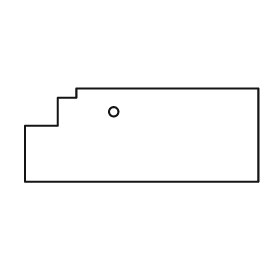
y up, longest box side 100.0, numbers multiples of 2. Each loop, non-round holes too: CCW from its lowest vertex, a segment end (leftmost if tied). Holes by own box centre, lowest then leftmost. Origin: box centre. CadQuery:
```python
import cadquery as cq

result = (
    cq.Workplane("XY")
    .moveTo(-50.0, -20.0)
    .lineTo(50.0, -20.0)
    .lineTo(50.0, 20.0)
    .lineTo(-28.0, 20.0)
    .lineTo(-28.0, 16.0)
    .lineTo(-36.0, 16.0)
    .lineTo(-36.0, 4.0)
    .lineTo(-50.0, 4.0)
    .close()
    .moveTo(-12.0, 10.0)
    .circle(2.0)
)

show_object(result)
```